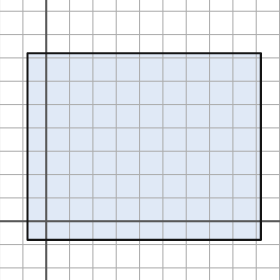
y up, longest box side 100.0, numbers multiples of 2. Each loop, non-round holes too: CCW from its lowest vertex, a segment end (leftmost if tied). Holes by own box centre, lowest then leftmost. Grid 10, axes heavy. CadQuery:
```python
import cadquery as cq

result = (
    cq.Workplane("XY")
    .moveTo(-8.0, -8.0)
    .lineTo(92.0, -8.0)
    .lineTo(92.0, 72.0)
    .lineTo(-8.0, 72.0)
    .close()
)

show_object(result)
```